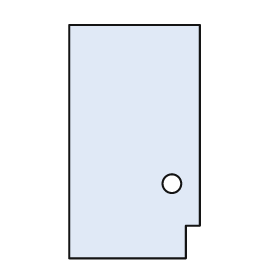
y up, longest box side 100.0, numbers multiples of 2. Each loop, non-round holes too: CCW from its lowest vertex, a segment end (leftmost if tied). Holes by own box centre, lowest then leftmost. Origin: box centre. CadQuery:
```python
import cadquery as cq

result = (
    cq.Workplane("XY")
    .moveTo(-28.0, -50.0)
    .lineTo(22.0, -50.0)
    .lineTo(22.0, -36.0)
    .lineTo(28.0, -36.0)
    .lineTo(28.0, 50.0)
    .lineTo(-28.0, 50.0)
    .close()
    .moveTo(16.0, -18.0)
    .circle(4.0)
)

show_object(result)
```